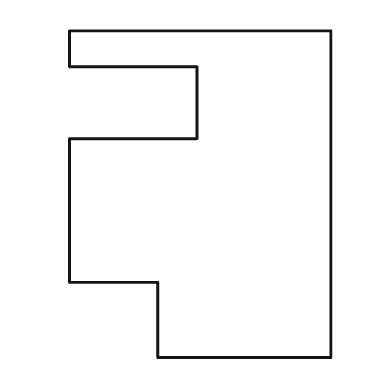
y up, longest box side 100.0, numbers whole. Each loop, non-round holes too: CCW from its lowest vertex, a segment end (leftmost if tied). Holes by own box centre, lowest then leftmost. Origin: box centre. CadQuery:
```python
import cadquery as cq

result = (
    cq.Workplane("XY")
    .moveTo(-13.0, -50.0)
    .lineTo(40.0, -50.0)
    .lineTo(40.0, 50.0)
    .lineTo(-40.0, 50.0)
    .lineTo(-40.0, 39.0)
    .lineTo(-1.0, 39.0)
    .lineTo(-1.0, 17.0)
    .lineTo(-40.0, 17.0)
    .lineTo(-40.0, -27.0)
    .lineTo(-13.0, -27.0)
    .close()
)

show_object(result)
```